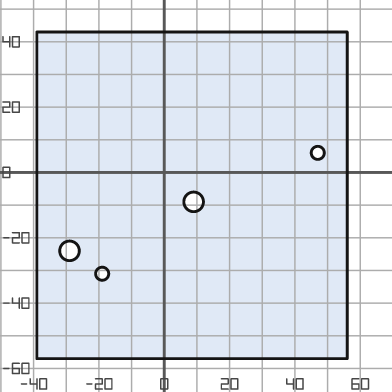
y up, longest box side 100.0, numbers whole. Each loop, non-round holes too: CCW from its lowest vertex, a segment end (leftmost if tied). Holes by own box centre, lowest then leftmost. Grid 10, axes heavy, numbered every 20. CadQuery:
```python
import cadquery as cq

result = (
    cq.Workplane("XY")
    .moveTo(-39.0, -57.0)
    .lineTo(56.0, -57.0)
    .lineTo(56.0, 43.0)
    .lineTo(-39.0, 43.0)
    .close()
    .moveTo(-19.0, -31.0)
    .circle(2.0)
    .moveTo(-29.0, -24.0)
    .circle(3.0)
    .moveTo(9.0, -9.0)
    .circle(3.0)
    .moveTo(47.0, 6.0)
    .circle(2.0)
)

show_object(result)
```